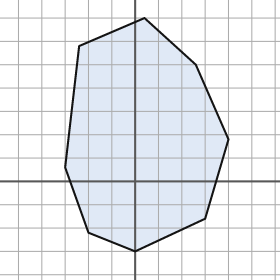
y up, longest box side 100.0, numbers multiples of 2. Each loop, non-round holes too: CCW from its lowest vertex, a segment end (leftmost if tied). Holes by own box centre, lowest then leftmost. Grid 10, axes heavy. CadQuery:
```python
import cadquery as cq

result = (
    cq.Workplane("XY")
    .moveTo(0.0, -30.0)
    .lineTo(30.0, -16.0)
    .lineTo(40.0, 18.0)
    .lineTo(26.0, 50.0)
    .lineTo(4.0, 70.0)
    .lineTo(-24.0, 58.0)
    .lineTo(-30.0, 6.0)
    .lineTo(-20.0, -22.0)
    .close()
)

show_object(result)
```